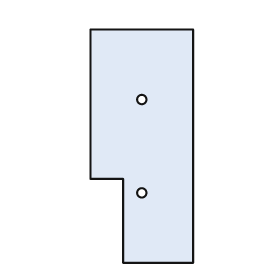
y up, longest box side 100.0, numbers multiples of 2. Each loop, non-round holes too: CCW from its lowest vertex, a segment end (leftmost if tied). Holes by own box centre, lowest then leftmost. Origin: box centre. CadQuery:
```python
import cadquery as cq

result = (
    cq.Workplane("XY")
    .moveTo(-8.0, -50.0)
    .lineTo(22.0, -50.0)
    .lineTo(22.0, 50.0)
    .lineTo(-22.0, 50.0)
    .lineTo(-22.0, -14.0)
    .lineTo(-8.0, -14.0)
    .close()
    .moveTo(0.0, -20.0)
    .circle(2.0)
    .moveTo(0.0, 20.0)
    .circle(2.0)
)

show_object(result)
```